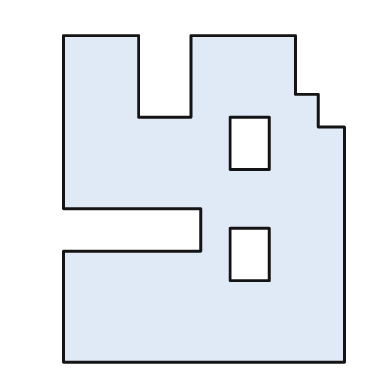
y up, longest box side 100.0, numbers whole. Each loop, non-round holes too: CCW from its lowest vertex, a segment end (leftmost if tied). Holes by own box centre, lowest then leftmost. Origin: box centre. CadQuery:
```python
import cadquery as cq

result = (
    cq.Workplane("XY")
    .moveTo(-43.0, -50.0)
    .lineTo(43.0, -50.0)
    .lineTo(43.0, 22.0)
    .lineTo(35.0, 22.0)
    .lineTo(35.0, 32.0)
    .lineTo(28.0, 32.0)
    .lineTo(28.0, 50.0)
    .lineTo(-4.0, 50.0)
    .lineTo(-4.0, 25.0)
    .lineTo(-20.0, 25.0)
    .lineTo(-20.0, 50.0)
    .lineTo(-43.0, 50.0)
    .lineTo(-43.0, -3.0)
    .lineTo(-1.0, -3.0)
    .lineTo(-1.0, -16.0)
    .lineTo(-43.0, -16.0)
    .close()
    .moveTo(8.0, -25.0)
    .lineTo(20.0, -25.0)
    .lineTo(20.0, -9.0)
    .lineTo(8.0, -9.0)
    .close()
    .moveTo(8.0, 9.0)
    .lineTo(20.0, 9.0)
    .lineTo(20.0, 25.0)
    .lineTo(8.0, 25.0)
    .close()
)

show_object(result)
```